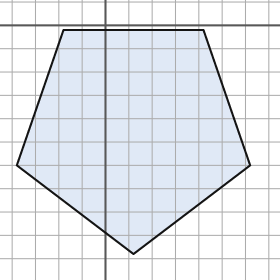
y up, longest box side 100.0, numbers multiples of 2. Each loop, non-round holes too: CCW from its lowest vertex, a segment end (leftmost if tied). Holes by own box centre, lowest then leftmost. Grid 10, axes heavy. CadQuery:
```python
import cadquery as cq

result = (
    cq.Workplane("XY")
    .moveTo(12.0, -98.0)
    .lineTo(62.0, -60.0)
    .lineTo(42.0, -2.0)
    .lineTo(-18.0, -2.0)
    .lineTo(-38.0, -60.0)
    .close()
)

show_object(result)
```